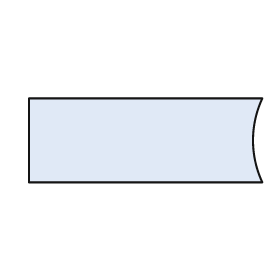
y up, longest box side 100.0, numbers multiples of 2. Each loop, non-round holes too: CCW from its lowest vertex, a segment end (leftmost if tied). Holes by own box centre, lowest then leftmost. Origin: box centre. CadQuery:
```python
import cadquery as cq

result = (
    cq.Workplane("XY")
    .moveTo(-50.0, -18.0)
    .lineTo(50.0, -18.0)
    .threePointArc((46.0, 0.0), (50.0, 18.0))
    .lineTo(-50.0, 18.0)
    .close()
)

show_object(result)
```